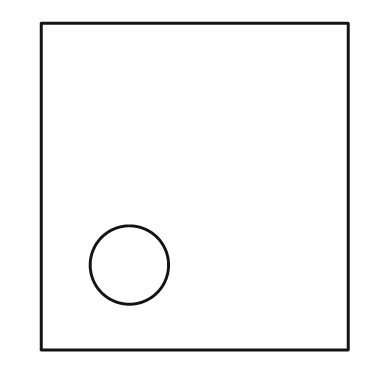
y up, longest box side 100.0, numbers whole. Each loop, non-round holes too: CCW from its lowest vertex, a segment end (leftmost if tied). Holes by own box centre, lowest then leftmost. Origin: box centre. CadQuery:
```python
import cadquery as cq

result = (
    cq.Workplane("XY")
    .moveTo(-47.0, -50.0)
    .lineTo(47.0, -50.0)
    .lineTo(47.0, 50.0)
    .lineTo(-47.0, 50.0)
    .close()
    .moveTo(-20.0, -24.0)
    .circle(12.0)
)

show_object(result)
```